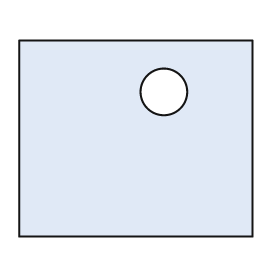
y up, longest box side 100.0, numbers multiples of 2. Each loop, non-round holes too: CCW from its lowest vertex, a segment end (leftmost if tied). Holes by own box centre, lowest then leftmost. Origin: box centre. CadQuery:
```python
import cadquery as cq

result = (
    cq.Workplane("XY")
    .moveTo(-50.0, -42.0)
    .lineTo(50.0, -42.0)
    .lineTo(50.0, 42.0)
    .lineTo(-50.0, 42.0)
    .close()
    .moveTo(12.0, 20.0)
    .circle(10.0)
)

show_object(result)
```